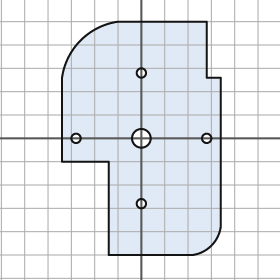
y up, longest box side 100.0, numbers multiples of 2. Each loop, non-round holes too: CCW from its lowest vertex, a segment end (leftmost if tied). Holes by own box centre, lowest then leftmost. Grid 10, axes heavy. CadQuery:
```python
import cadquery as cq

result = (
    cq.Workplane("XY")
    .moveTo(-14.0, -50.0)
    .lineTo(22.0, -50.0)
    .threePointArc((30.0, -46.0), (34.0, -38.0))
    .lineTo(34.0, 26.0)
    .lineTo(28.0, 26.0)
    .lineTo(28.0, 50.0)
    .lineTo(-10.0, 50.0)
    .threePointArc((-26.0, 42.0), (-34.0, 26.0))
    .lineTo(-34.0, -10.0)
    .lineTo(-14.0, -10.0)
    .close()
    .moveTo(0.0, -28.0)
    .circle(2.0)
    .moveTo(-28.0, 0.0)
    .circle(2.0)
    .moveTo(0.0, 0.0)
    .circle(4.0)
    .moveTo(28.0, 0.0)
    .circle(2.0)
    .moveTo(0.0, 28.0)
    .circle(2.0)
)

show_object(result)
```